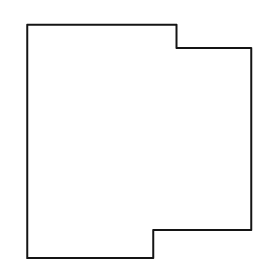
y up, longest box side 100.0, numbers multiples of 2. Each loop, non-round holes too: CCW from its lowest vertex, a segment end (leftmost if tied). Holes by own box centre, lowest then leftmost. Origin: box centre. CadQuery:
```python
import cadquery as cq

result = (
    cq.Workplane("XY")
    .moveTo(-48.0, -50.0)
    .lineTo(6.0, -50.0)
    .lineTo(6.0, -38.0)
    .lineTo(48.0, -38.0)
    .lineTo(48.0, 40.0)
    .lineTo(16.0, 40.0)
    .lineTo(16.0, 50.0)
    .lineTo(-48.0, 50.0)
    .close()
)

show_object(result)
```